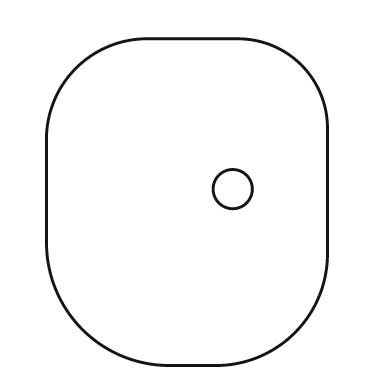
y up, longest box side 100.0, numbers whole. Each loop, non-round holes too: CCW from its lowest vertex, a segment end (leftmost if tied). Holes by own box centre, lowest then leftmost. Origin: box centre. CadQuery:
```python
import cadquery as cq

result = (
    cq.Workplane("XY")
    .moveTo(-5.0, -50.0)
    .lineTo(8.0, -50.0)
    .threePointArc((33.0, -40.0), (43.0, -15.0))
    .lineTo(43.0, 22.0)
    .threePointArc((35.0, 42.0), (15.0, 50.0))
    .lineTo(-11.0, 50.0)
    .threePointArc((-34.0, 41.0), (-43.0, 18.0))
    .lineTo(-43.0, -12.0)
    .threePointArc((-32.0, -39.0), (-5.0, -50.0))
    .close()
    .moveTo(14.0, 4.0)
    .circle(6.0)
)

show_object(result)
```